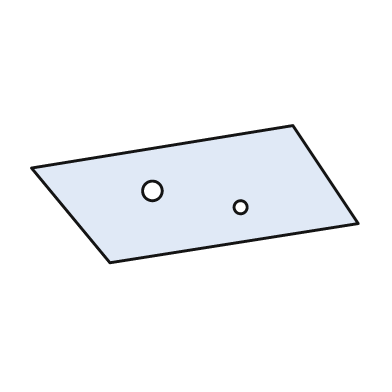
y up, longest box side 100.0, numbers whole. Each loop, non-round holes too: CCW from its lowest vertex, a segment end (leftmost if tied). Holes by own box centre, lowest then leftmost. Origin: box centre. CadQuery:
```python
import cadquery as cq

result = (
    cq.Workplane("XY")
    .moveTo(-26.0, -21.0)
    .lineTo(50.0, -9.0)
    .lineTo(30.0, 21.0)
    .lineTo(-50.0, 8.0)
    .close()
    .moveTo(14.0, -4.0)
    .circle(2.0)
    .moveTo(-13.0, 1.0)
    .circle(3.0)
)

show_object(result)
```